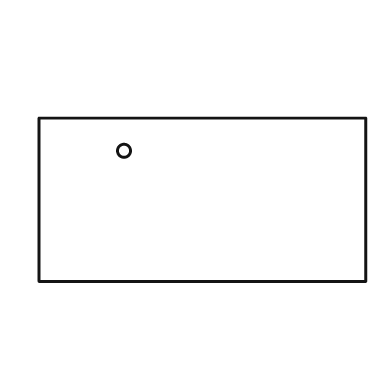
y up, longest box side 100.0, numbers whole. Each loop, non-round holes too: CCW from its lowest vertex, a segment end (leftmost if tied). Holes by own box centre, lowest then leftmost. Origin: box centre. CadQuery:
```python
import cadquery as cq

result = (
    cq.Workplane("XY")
    .moveTo(-50.0, -25.0)
    .lineTo(50.0, -25.0)
    .lineTo(50.0, 25.0)
    .lineTo(-50.0, 25.0)
    .close()
    .moveTo(-24.0, 15.0)
    .circle(2.0)
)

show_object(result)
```